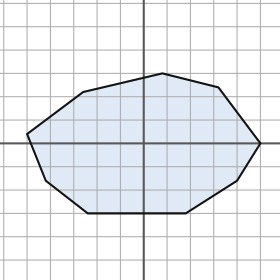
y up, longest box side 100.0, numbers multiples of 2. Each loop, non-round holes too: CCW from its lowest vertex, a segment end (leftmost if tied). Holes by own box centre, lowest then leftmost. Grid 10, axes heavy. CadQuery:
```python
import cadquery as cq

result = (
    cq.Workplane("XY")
    .moveTo(-24.0, -30.0)
    .lineTo(18.0, -30.0)
    .lineTo(40.0, -16.0)
    .lineTo(50.0, 0.0)
    .lineTo(32.0, 24.0)
    .lineTo(8.0, 30.0)
    .lineTo(-26.0, 22.0)
    .lineTo(-50.0, 4.0)
    .lineTo(-42.0, -16.0)
    .close()
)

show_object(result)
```